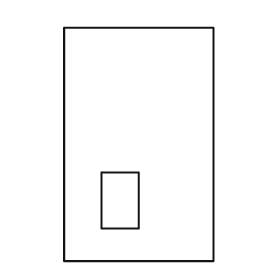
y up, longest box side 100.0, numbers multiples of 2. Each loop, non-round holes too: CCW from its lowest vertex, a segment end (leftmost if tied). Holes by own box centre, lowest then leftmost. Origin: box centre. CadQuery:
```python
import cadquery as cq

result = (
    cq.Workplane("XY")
    .moveTo(-32.0, -50.0)
    .lineTo(32.0, -50.0)
    .lineTo(32.0, 50.0)
    .lineTo(-32.0, 50.0)
    .close()
    .moveTo(-16.0, -36.0)
    .lineTo(0.0, -36.0)
    .lineTo(0.0, -12.0)
    .lineTo(-16.0, -12.0)
    .close()
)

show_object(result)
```